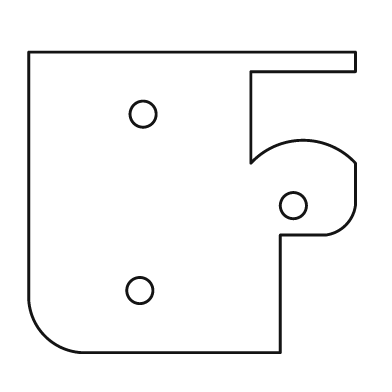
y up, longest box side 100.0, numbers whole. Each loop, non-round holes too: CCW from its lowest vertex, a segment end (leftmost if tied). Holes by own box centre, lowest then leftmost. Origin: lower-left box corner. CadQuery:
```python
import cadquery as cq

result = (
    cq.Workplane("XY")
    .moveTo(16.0, 0.0)
    .lineTo(77.0, 0.0)
    .lineTo(77.0, 36.0)
    .lineTo(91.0, 36.0)
    .threePointArc((97.0, 39.0), (100.0, 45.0))
    .lineTo(100.0, 58.0)
    .threePointArc((84.0, 65.0), (68.0, 58.0))
    .lineTo(68.0, 86.0)
    .lineTo(100.0, 86.0)
    .lineTo(100.0, 92.0)
    .lineTo(0.0, 92.0)
    .lineTo(0.0, 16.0)
    .threePointArc((5.0, 5.0), (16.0, 0.0))
    .close()
    .moveTo(34.0, 19.0)
    .circle(4.0)
    .moveTo(81.0, 45.0)
    .circle(4.0)
    .moveTo(35.0, 73.0)
    .circle(4.0)
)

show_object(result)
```